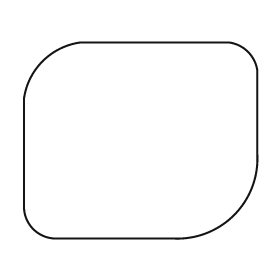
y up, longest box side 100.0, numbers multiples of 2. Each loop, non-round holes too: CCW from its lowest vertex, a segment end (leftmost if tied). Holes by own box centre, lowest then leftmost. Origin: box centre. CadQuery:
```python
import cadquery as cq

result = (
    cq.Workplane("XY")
    .moveTo(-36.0, -42.0)
    .lineTo(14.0, -42.0)
    .threePointArc((40.0, -32.0), (50.0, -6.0))
    .lineTo(50.0, 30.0)
    .threePointArc((46.0, 38.0), (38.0, 42.0))
    .lineTo(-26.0, 42.0)
    .threePointArc((-42.0, 34.0), (-50.0, 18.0))
    .lineTo(-50.0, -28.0)
    .threePointArc((-46.0, -38.0), (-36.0, -42.0))
    .close()
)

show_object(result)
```